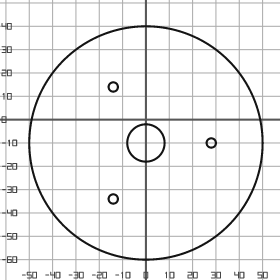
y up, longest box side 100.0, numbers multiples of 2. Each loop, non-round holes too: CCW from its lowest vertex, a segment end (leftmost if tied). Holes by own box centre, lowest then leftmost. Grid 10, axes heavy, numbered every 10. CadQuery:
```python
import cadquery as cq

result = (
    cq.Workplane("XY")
    .moveTo(0.0, -10.0)
    .circle(50.0)
    .moveTo(-14.0, -34.0)
    .circle(2.0)
    .moveTo(0.0, -10.0)
    .circle(8.0)
    .moveTo(28.0, -10.0)
    .circle(2.0)
    .moveTo(-14.0, 14.0)
    .circle(2.0)
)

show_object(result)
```